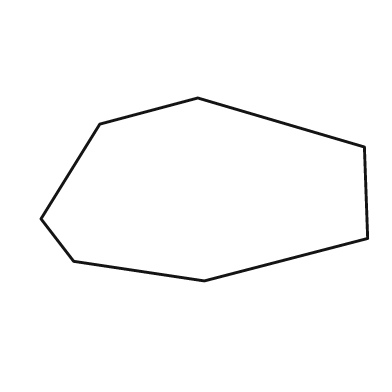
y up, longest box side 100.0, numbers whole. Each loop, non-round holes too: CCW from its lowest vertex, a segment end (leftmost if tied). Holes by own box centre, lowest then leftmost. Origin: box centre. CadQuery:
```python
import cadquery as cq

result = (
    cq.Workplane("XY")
    .moveTo(0.0, -28.0)
    .lineTo(50.0, -15.0)
    .lineTo(49.0, 13.0)
    .lineTo(-2.0, 28.0)
    .lineTo(-32.0, 20.0)
    .lineTo(-50.0, -9.0)
    .lineTo(-40.0, -22.0)
    .close()
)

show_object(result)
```